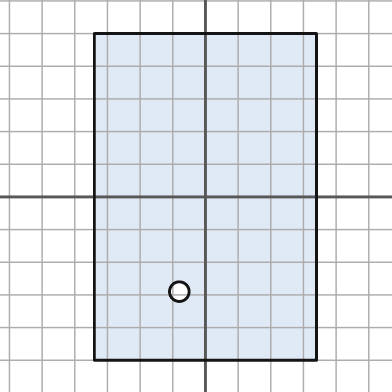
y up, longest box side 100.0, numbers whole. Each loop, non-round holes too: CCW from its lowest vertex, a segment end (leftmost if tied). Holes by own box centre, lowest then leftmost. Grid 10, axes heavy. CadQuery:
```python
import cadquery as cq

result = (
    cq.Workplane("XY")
    .moveTo(-34.0, -50.0)
    .lineTo(34.0, -50.0)
    .lineTo(34.0, 50.0)
    .lineTo(-34.0, 50.0)
    .close()
    .moveTo(-8.0, -29.0)
    .circle(3.0)
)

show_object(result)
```